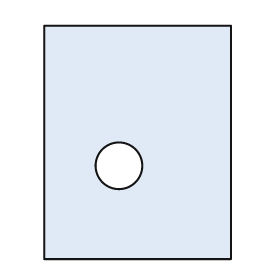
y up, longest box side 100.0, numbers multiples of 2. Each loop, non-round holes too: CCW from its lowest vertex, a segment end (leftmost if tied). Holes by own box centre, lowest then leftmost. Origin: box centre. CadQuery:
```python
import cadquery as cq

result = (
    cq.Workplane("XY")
    .moveTo(-40.0, -50.0)
    .lineTo(40.0, -50.0)
    .lineTo(40.0, 50.0)
    .lineTo(-40.0, 50.0)
    .close()
    .moveTo(-8.0, -10.0)
    .circle(10.0)
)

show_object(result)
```